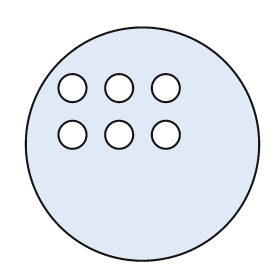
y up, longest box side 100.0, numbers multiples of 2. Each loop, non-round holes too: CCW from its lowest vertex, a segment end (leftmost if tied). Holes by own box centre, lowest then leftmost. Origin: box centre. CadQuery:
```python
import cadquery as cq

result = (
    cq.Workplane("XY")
    .moveTo(0.0, 0.0)
    .circle(50.0)
    .moveTo(-30.0, 4.0)
    .circle(6.0)
    .moveTo(-10.0, 4.0)
    .circle(6.0)
    .moveTo(10.0, 4.0)
    .circle(6.0)
    .moveTo(-30.0, 24.0)
    .circle(6.0)
    .moveTo(-10.0, 24.0)
    .circle(6.0)
    .moveTo(10.0, 24.0)
    .circle(6.0)
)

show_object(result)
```